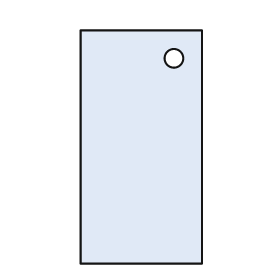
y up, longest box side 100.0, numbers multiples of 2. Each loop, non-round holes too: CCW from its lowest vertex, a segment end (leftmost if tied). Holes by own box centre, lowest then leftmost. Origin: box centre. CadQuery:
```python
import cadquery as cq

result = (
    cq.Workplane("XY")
    .moveTo(-26.0, -50.0)
    .lineTo(26.0, -50.0)
    .lineTo(26.0, 50.0)
    .lineTo(-26.0, 50.0)
    .close()
    .moveTo(14.0, 38.0)
    .circle(4.0)
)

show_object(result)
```